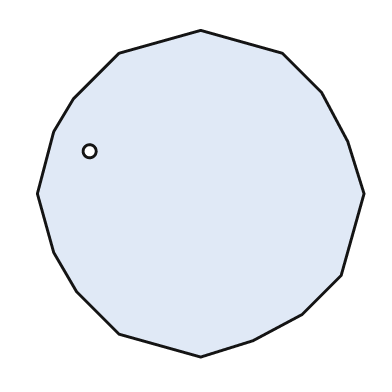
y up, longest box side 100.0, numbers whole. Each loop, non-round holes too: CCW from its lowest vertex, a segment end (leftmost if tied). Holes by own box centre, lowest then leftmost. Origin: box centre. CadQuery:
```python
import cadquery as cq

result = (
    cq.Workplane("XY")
    .moveTo(0.0, -50.0)
    .lineTo(16.0, -45.0)
    .lineTo(31.0, -37.0)
    .lineTo(43.0, -25.0)
    .lineTo(50.0, 0.0)
    .lineTo(45.0, 16.0)
    .lineTo(37.0, 31.0)
    .lineTo(25.0, 43.0)
    .lineTo(0.0, 50.0)
    .lineTo(-25.0, 43.0)
    .lineTo(-39.0, 29.0)
    .lineTo(-45.0, 19.0)
    .lineTo(-50.0, 0.0)
    .lineTo(-45.0, -18.0)
    .lineTo(-38.0, -30.0)
    .lineTo(-25.0, -43.0)
    .close()
    .moveTo(-34.0, 13.0)
    .circle(2.0)
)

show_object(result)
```